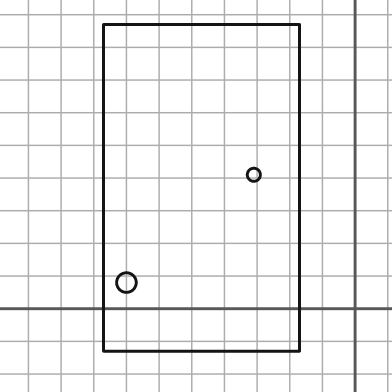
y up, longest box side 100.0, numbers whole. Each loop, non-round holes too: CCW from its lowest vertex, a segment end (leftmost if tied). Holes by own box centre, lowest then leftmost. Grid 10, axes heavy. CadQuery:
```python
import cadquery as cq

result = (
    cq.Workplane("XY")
    .moveTo(-77.0, -13.0)
    .lineTo(-17.0, -13.0)
    .lineTo(-17.0, 87.0)
    .lineTo(-77.0, 87.0)
    .close()
    .moveTo(-70.0, 8.0)
    .circle(3.0)
    .moveTo(-31.0, 41.0)
    .circle(2.0)
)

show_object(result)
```